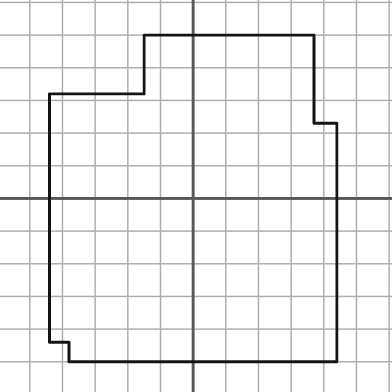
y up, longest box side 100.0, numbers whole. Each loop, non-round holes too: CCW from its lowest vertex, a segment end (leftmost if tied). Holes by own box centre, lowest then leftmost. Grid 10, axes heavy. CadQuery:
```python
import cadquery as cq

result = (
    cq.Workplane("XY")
    .moveTo(-38.0, -50.0)
    .lineTo(44.0, -50.0)
    .lineTo(44.0, 23.0)
    .lineTo(37.0, 23.0)
    .lineTo(37.0, 50.0)
    .lineTo(-15.0, 50.0)
    .lineTo(-15.0, 32.0)
    .lineTo(-44.0, 32.0)
    .lineTo(-44.0, -44.0)
    .lineTo(-38.0, -44.0)
    .close()
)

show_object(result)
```